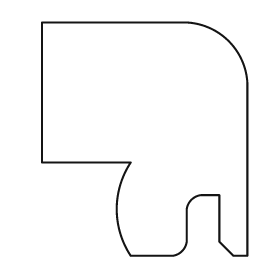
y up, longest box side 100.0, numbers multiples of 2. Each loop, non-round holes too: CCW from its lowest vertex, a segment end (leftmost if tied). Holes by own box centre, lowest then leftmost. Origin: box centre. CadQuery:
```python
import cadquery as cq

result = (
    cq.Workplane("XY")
    .moveTo(-6.0, -50.0)
    .lineTo(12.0, -50.0)
    .threePointArc((16.0, -48.0), (18.0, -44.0))
    .lineTo(18.0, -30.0)
    .threePointArc((20.0, -26.0), (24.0, -24.0))
    .lineTo(32.0, -24.0)
    .lineTo(32.0, -44.0)
    .lineTo(38.0, -50.0)
    .lineTo(44.0, -50.0)
    .lineTo(44.0, 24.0)
    .threePointArc((36.0, 42.0), (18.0, 50.0))
    .lineTo(-44.0, 50.0)
    .lineTo(-44.0, -10.0)
    .lineTo(-6.0, -10.0)
    .threePointArc((-12.0, -30.0), (-6.0, -50.0))
    .close()
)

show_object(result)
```